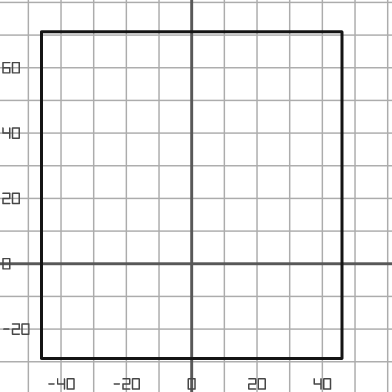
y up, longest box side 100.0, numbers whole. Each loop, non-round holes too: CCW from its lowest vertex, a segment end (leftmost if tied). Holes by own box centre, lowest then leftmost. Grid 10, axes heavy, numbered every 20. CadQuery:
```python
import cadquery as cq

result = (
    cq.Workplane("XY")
    .moveTo(-46.0, -29.0)
    .lineTo(46.0, -29.0)
    .lineTo(46.0, 71.0)
    .lineTo(-46.0, 71.0)
    .close()
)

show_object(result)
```